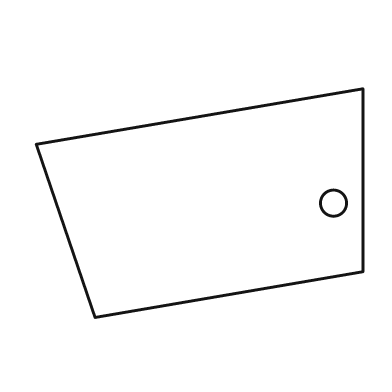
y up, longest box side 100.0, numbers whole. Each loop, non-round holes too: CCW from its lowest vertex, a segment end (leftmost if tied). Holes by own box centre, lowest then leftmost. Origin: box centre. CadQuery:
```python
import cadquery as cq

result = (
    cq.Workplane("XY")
    .moveTo(-32.0, -35.0)
    .lineTo(50.0, -21.0)
    .lineTo(50.0, 35.0)
    .lineTo(-50.0, 18.0)
    .close()
    .moveTo(41.0, 0.0)
    .circle(4.0)
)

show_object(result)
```